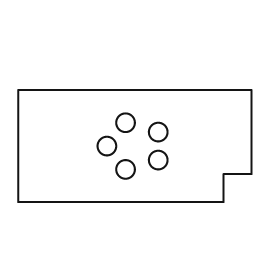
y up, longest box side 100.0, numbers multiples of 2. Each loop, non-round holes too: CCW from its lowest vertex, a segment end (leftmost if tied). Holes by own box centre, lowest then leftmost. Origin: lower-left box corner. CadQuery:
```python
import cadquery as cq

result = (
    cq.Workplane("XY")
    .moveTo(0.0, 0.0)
    .lineTo(88.0, 0.0)
    .lineTo(88.0, 12.0)
    .lineTo(100.0, 12.0)
    .lineTo(100.0, 48.0)
    .lineTo(0.0, 48.0)
    .close()
    .moveTo(46.0, 14.0)
    .circle(4.0)
    .moveTo(60.0, 18.0)
    .circle(4.0)
    .moveTo(38.0, 24.0)
    .circle(4.0)
    .moveTo(60.0, 30.0)
    .circle(4.0)
    .moveTo(46.0, 34.0)
    .circle(4.0)
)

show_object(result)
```